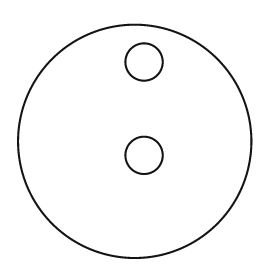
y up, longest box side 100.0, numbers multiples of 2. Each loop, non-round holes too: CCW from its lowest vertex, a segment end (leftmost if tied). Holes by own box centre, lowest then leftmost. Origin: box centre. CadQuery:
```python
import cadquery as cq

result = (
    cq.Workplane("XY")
    .moveTo(0.0, 0.0)
    .circle(50.0)
    .moveTo(4.0, -6.0)
    .circle(8.0)
    .moveTo(4.0, 34.0)
    .circle(8.0)
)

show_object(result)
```